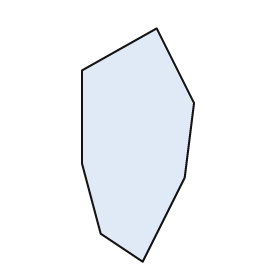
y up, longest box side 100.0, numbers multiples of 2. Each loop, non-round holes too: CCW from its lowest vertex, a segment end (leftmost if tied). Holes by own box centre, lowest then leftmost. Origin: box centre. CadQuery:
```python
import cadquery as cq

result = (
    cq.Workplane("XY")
    .moveTo(2.0, -50.0)
    .lineTo(20.0, -14.0)
    .lineTo(24.0, 18.0)
    .lineTo(8.0, 50.0)
    .lineTo(-24.0, 32.0)
    .lineTo(-24.0, -8.0)
    .lineTo(-16.0, -38.0)
    .close()
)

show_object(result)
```